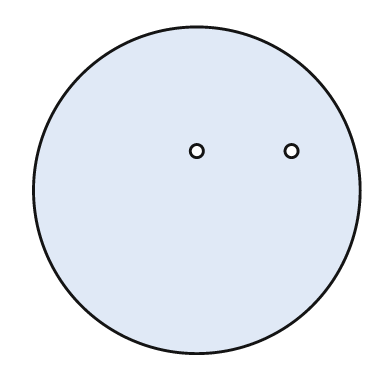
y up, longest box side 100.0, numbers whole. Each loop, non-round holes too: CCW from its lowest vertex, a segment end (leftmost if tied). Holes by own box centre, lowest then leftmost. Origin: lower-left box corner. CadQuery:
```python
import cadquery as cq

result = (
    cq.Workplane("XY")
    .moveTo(50.0, 50.0)
    .circle(50.0)
    .moveTo(50.0, 62.0)
    .circle(2.0)
    .moveTo(79.0, 62.0)
    .circle(2.0)
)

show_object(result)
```